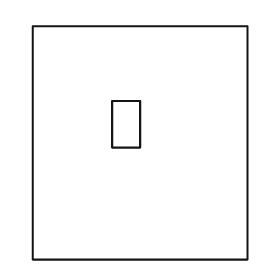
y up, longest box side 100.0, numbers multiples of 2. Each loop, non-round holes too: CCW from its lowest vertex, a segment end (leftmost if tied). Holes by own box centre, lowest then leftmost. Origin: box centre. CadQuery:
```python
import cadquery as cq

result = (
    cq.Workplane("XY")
    .moveTo(-46.0, -50.0)
    .lineTo(46.0, -50.0)
    .lineTo(46.0, 50.0)
    .lineTo(-46.0, 50.0)
    .close()
    .moveTo(-12.0, -2.0)
    .lineTo(0.0, -2.0)
    .lineTo(0.0, 18.0)
    .lineTo(-12.0, 18.0)
    .close()
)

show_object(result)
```